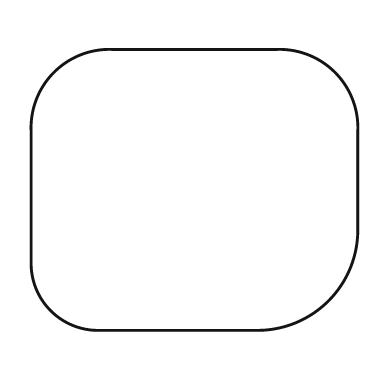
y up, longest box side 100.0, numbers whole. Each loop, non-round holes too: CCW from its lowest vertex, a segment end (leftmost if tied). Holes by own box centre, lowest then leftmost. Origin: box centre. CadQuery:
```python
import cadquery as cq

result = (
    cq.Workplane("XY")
    .moveTo(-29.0, -43.0)
    .lineTo(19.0, -43.0)
    .threePointArc((41.0, -34.0), (50.0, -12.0))
    .lineTo(50.0, 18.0)
    .threePointArc((43.0, 36.0), (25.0, 43.0))
    .lineTo(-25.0, 43.0)
    .threePointArc((-43.0, 36.0), (-50.0, 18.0))
    .lineTo(-50.0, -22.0)
    .threePointArc((-44.0, -37.0), (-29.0, -43.0))
    .close()
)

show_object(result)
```